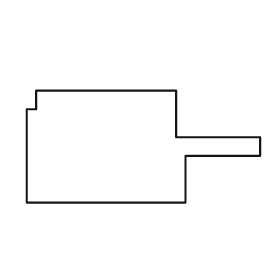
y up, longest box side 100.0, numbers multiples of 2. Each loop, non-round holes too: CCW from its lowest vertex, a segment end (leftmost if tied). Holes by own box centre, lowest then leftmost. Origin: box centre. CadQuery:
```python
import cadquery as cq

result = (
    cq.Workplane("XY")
    .moveTo(-50.0, -24.0)
    .lineTo(18.0, -24.0)
    .lineTo(18.0, -4.0)
    .lineTo(50.0, -4.0)
    .lineTo(50.0, 4.0)
    .lineTo(14.0, 4.0)
    .lineTo(14.0, 24.0)
    .lineTo(-46.0, 24.0)
    .lineTo(-46.0, 16.0)
    .lineTo(-50.0, 16.0)
    .close()
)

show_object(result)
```